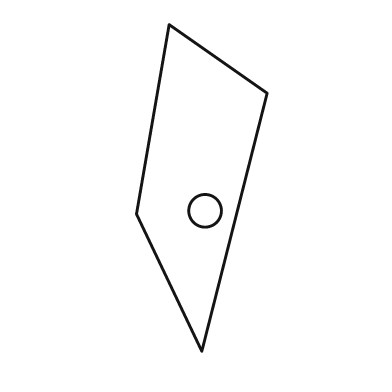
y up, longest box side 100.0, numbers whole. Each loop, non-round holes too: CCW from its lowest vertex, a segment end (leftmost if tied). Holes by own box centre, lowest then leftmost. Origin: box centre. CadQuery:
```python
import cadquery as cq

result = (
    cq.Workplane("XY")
    .moveTo(0.0, -50.0)
    .lineTo(20.0, 29.0)
    .lineTo(-10.0, 50.0)
    .lineTo(-20.0, -8.0)
    .close()
    .moveTo(1.0, -7.0)
    .circle(5.0)
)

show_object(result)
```